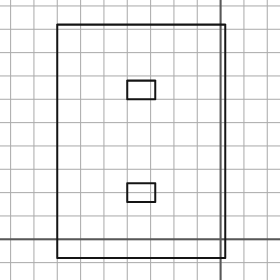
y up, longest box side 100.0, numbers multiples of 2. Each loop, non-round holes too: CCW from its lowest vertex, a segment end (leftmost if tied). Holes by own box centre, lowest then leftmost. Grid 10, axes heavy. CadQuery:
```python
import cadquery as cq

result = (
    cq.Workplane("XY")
    .moveTo(-70.0, -8.0)
    .lineTo(2.0, -8.0)
    .lineTo(2.0, 92.0)
    .lineTo(-70.0, 92.0)
    .close()
    .moveTo(-40.0, 16.0)
    .lineTo(-28.0, 16.0)
    .lineTo(-28.0, 24.0)
    .lineTo(-40.0, 24.0)
    .close()
    .moveTo(-40.0, 60.0)
    .lineTo(-28.0, 60.0)
    .lineTo(-28.0, 68.0)
    .lineTo(-40.0, 68.0)
    .close()
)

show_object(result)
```